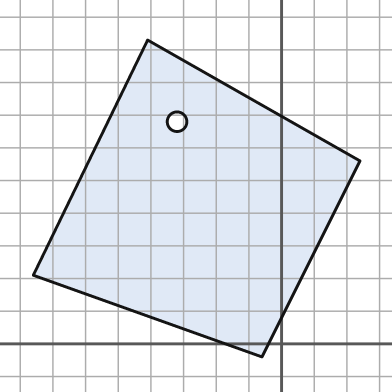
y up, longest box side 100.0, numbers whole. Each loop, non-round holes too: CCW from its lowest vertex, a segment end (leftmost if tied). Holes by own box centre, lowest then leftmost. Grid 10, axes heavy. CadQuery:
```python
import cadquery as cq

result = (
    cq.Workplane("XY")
    .moveTo(-6.0, -4.0)
    .lineTo(24.0, 56.0)
    .lineTo(-41.0, 93.0)
    .lineTo(-76.0, 21.0)
    .close()
    .moveTo(-32.0, 68.0)
    .circle(3.0)
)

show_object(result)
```